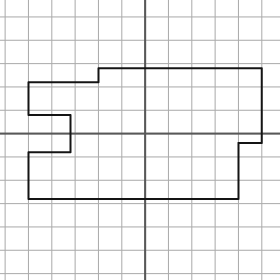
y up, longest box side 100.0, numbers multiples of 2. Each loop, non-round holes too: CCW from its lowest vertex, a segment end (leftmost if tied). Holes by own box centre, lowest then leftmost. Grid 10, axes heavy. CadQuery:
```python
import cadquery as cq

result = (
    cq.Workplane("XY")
    .moveTo(-50.0, -28.0)
    .lineTo(40.0, -28.0)
    .lineTo(40.0, -4.0)
    .lineTo(50.0, -4.0)
    .lineTo(50.0, 28.0)
    .lineTo(-20.0, 28.0)
    .lineTo(-20.0, 22.0)
    .lineTo(-50.0, 22.0)
    .lineTo(-50.0, 8.0)
    .lineTo(-32.0, 8.0)
    .lineTo(-32.0, -8.0)
    .lineTo(-50.0, -8.0)
    .close()
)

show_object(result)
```